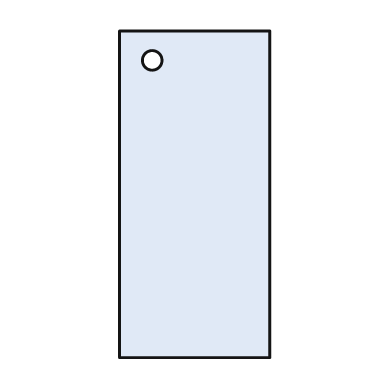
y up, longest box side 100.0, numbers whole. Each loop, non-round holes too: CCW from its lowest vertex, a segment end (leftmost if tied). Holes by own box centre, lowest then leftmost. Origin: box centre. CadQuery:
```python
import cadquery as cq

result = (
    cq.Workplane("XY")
    .moveTo(-23.0, -50.0)
    .lineTo(23.0, -50.0)
    .lineTo(23.0, 50.0)
    .lineTo(-23.0, 50.0)
    .close()
    .moveTo(-13.0, 41.0)
    .circle(3.0)
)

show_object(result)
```